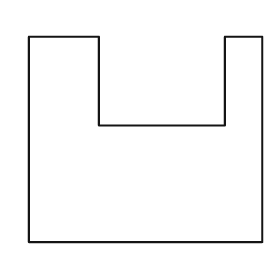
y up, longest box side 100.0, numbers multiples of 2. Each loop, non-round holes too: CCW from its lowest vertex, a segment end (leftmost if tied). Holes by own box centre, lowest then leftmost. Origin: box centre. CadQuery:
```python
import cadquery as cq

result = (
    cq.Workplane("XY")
    .moveTo(-50.0, -44.0)
    .lineTo(50.0, -44.0)
    .lineTo(50.0, 44.0)
    .lineTo(34.0, 44.0)
    .lineTo(34.0, 6.0)
    .lineTo(-20.0, 6.0)
    .lineTo(-20.0, 44.0)
    .lineTo(-50.0, 44.0)
    .close()
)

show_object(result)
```